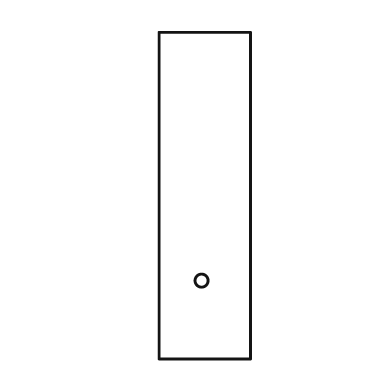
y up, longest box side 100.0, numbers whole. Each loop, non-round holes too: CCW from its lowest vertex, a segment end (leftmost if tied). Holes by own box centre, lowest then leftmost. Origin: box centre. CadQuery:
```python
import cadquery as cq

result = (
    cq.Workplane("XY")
    .moveTo(-14.0, -50.0)
    .lineTo(14.0, -50.0)
    .lineTo(14.0, 50.0)
    .lineTo(-14.0, 50.0)
    .close()
    .moveTo(-1.0, -26.0)
    .circle(2.0)
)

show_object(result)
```